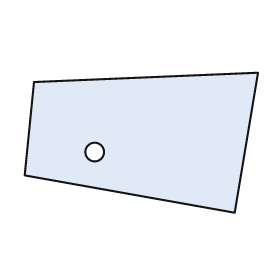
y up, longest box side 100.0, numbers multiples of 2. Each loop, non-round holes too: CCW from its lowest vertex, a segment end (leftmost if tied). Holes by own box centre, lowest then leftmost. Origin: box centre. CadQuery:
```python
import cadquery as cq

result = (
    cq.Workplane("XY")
    .moveTo(40.0, -30.0)
    .lineTo(50.0, 30.0)
    .lineTo(-46.0, 26.0)
    .lineTo(-50.0, -14.0)
    .close()
    .moveTo(-20.0, -4.0)
    .circle(4.0)
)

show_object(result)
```